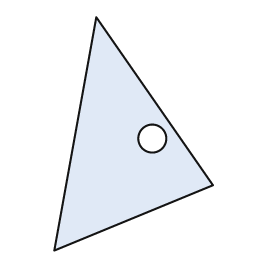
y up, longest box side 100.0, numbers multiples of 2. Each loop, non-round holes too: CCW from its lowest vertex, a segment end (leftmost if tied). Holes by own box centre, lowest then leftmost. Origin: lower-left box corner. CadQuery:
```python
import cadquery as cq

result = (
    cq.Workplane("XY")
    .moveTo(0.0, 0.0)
    .lineTo(68.0, 28.0)
    .lineTo(18.0, 100.0)
    .close()
    .moveTo(42.0, 48.0)
    .circle(6.0)
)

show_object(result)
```